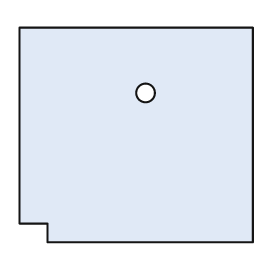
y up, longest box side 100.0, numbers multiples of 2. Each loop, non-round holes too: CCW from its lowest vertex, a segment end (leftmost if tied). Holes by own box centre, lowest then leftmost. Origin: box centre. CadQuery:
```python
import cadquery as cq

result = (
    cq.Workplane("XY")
    .moveTo(-38.0, -46.0)
    .lineTo(50.0, -46.0)
    .lineTo(50.0, 46.0)
    .lineTo(-50.0, 46.0)
    .lineTo(-50.0, -38.0)
    .lineTo(-38.0, -38.0)
    .close()
    .moveTo(4.0, 18.0)
    .circle(4.0)
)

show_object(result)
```